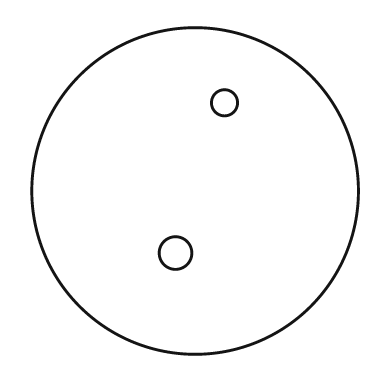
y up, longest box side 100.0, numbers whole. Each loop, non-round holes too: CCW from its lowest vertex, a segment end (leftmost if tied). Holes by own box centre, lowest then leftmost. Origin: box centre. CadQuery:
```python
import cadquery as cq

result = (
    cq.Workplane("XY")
    .moveTo(0.0, 0.0)
    .circle(50.0)
    .moveTo(-6.0, -19.0)
    .circle(5.0)
    .moveTo(9.0, 27.0)
    .circle(4.0)
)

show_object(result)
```